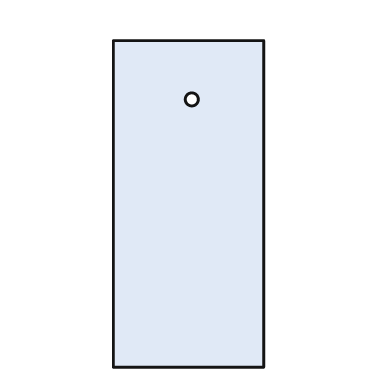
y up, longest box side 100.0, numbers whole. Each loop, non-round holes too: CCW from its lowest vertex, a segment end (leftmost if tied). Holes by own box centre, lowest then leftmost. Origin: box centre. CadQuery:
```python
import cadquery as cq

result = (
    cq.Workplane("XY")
    .moveTo(-23.0, -50.0)
    .lineTo(23.0, -50.0)
    .lineTo(23.0, 50.0)
    .lineTo(-23.0, 50.0)
    .close()
    .moveTo(1.0, 32.0)
    .circle(2.0)
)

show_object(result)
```